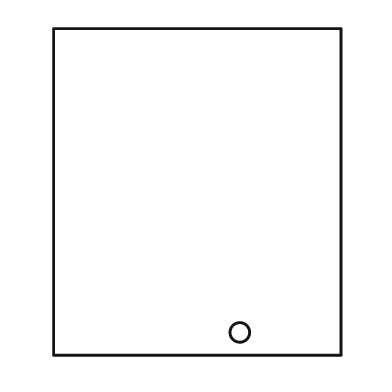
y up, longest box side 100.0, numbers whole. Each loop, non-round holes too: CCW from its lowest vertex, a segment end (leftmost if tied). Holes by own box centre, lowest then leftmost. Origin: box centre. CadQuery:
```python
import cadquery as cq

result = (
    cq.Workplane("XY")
    .moveTo(-44.0, -50.0)
    .lineTo(44.0, -50.0)
    .lineTo(44.0, 50.0)
    .lineTo(-44.0, 50.0)
    .close()
    .moveTo(13.0, -43.0)
    .circle(3.0)
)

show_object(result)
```